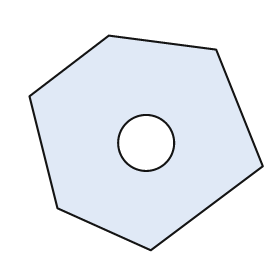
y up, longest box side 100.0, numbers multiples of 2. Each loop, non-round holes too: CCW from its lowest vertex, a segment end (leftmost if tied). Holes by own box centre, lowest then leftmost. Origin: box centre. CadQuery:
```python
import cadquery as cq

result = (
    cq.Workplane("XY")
    .moveTo(2.0, -46.0)
    .lineTo(50.0, -10.0)
    .lineTo(30.0, 40.0)
    .lineTo(-16.0, 46.0)
    .lineTo(-50.0, 20.0)
    .lineTo(-38.0, -28.0)
    .close()
    .moveTo(0.0, 0.0)
    .circle(12.0)
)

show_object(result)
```